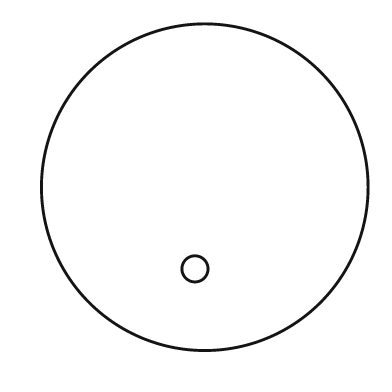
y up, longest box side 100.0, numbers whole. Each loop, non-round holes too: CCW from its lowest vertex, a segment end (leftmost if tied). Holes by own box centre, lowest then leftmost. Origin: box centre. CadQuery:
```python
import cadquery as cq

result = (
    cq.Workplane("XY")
    .moveTo(0.0, 0.0)
    .circle(50.0)
    .moveTo(-3.0, -25.0)
    .circle(4.0)
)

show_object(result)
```